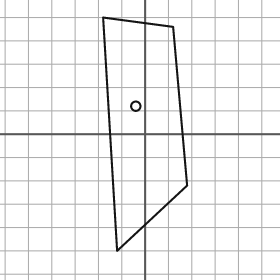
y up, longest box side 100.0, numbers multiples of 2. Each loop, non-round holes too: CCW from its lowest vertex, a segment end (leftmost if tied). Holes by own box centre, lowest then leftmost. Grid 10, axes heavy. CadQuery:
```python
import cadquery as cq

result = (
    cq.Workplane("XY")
    .moveTo(-12.0, -50.0)
    .lineTo(18.0, -22.0)
    .lineTo(12.0, 46.0)
    .lineTo(-18.0, 50.0)
    .close()
    .moveTo(-4.0, 12.0)
    .circle(2.0)
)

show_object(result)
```